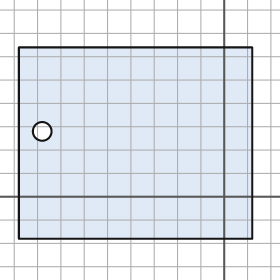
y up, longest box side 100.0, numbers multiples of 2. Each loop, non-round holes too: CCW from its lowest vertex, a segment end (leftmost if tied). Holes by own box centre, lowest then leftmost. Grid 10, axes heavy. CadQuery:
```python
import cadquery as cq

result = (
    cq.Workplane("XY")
    .moveTo(-88.0, -18.0)
    .lineTo(12.0, -18.0)
    .lineTo(12.0, 64.0)
    .lineTo(-88.0, 64.0)
    .close()
    .moveTo(-78.0, 28.0)
    .circle(4.0)
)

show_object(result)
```